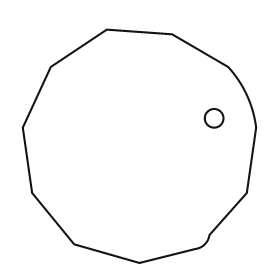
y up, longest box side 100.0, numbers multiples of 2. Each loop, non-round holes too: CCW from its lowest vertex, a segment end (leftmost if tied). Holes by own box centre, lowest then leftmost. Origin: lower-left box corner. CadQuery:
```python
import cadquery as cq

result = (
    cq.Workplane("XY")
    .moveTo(50.0, 0.0)
    .lineTo(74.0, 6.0)
    .threePointArc((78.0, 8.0), (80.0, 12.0))
    .lineTo(96.0, 30.0)
    .lineTo(100.0, 58.0)
    .threePointArc((96.0, 72.0), (88.0, 84.0))
    .lineTo(64.0, 98.0)
    .lineTo(36.0, 100.0)
    .lineTo(12.0, 84.0)
    .lineTo(0.0, 58.0)
    .lineTo(4.0, 30.0)
    .lineTo(22.0, 8.0)
    .close()
    .moveTo(82.0, 62.0)
    .circle(4.0)
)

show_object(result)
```